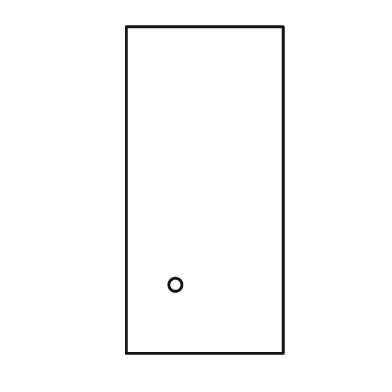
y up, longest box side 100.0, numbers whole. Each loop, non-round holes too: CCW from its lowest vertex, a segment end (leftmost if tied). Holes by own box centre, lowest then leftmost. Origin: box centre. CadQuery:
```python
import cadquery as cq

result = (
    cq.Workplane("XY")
    .moveTo(-24.0, -50.0)
    .lineTo(24.0, -50.0)
    .lineTo(24.0, 50.0)
    .lineTo(-24.0, 50.0)
    .close()
    .moveTo(-9.0, -29.0)
    .circle(2.0)
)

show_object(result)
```